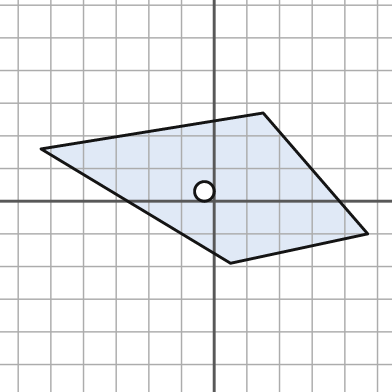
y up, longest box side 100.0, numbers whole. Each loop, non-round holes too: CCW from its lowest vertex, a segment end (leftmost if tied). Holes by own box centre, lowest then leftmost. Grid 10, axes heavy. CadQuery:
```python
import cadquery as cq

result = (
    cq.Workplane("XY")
    .moveTo(5.0, -19.0)
    .lineTo(47.0, -10.0)
    .lineTo(15.0, 27.0)
    .lineTo(-53.0, 16.0)
    .close()
    .moveTo(-3.0, 3.0)
    .circle(3.0)
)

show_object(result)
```